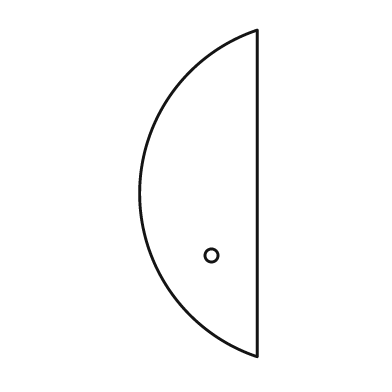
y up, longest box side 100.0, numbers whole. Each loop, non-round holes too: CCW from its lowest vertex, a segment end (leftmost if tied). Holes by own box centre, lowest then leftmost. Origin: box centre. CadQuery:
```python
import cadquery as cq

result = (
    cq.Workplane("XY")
    .moveTo(18.0, -50.0)
    .lineTo(18.0, 50.0)
    .threePointArc((-18.0, 0.0), (18.0, -50.0))
    .close()
    .moveTo(4.0, -19.0)
    .circle(2.0)
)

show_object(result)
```